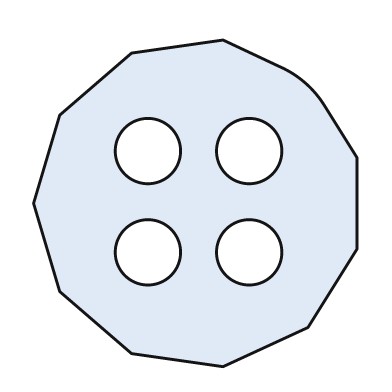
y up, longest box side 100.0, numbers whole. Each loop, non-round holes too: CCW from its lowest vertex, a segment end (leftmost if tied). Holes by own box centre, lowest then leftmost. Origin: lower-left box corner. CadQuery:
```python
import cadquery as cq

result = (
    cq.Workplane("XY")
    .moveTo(58.0, 0.0)
    .lineTo(84.0, 12.0)
    .lineTo(99.0, 36.0)
    .lineTo(99.0, 64.0)
    .lineTo(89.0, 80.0)
    .threePointArc((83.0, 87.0), (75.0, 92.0))
    .lineTo(58.0, 100.0)
    .lineTo(30.0, 96.0)
    .lineTo(8.0, 77.0)
    .lineTo(0.0, 50.0)
    .lineTo(8.0, 23.0)
    .lineTo(30.0, 4.0)
    .close()
    .moveTo(35.0, 35.0)
    .circle(10.0)
    .moveTo(66.0, 35.0)
    .circle(10.0)
    .moveTo(35.0, 66.0)
    .circle(10.0)
    .moveTo(66.0, 66.0)
    .circle(10.0)
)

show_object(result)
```